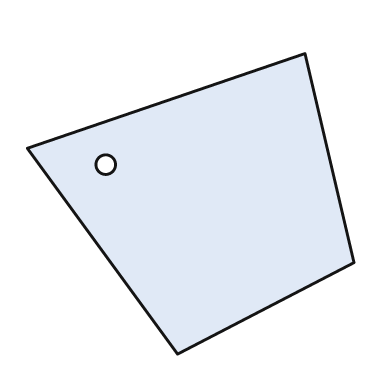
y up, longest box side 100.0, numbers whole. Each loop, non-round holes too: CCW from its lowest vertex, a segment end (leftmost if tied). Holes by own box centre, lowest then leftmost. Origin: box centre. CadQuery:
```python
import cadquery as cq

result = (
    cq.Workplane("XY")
    .moveTo(-4.0, -46.0)
    .lineTo(50.0, -18.0)
    .lineTo(35.0, 46.0)
    .lineTo(-50.0, 17.0)
    .close()
    .moveTo(-26.0, 12.0)
    .circle(3.0)
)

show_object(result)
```